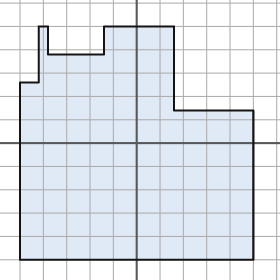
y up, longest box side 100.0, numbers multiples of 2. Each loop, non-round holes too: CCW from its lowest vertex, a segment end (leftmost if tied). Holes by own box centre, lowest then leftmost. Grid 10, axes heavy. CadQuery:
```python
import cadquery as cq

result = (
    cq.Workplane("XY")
    .moveTo(-50.0, -50.0)
    .lineTo(50.0, -50.0)
    .lineTo(50.0, 14.0)
    .lineTo(16.0, 14.0)
    .lineTo(16.0, 50.0)
    .lineTo(-14.0, 50.0)
    .lineTo(-14.0, 38.0)
    .lineTo(-38.0, 38.0)
    .lineTo(-38.0, 50.0)
    .lineTo(-42.0, 50.0)
    .lineTo(-42.0, 26.0)
    .lineTo(-50.0, 26.0)
    .close()
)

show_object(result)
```